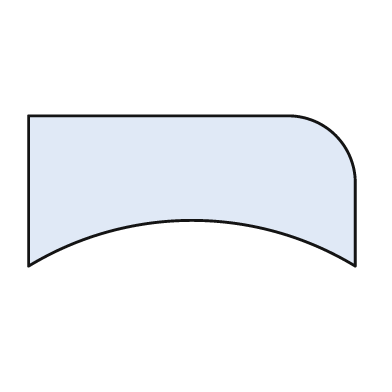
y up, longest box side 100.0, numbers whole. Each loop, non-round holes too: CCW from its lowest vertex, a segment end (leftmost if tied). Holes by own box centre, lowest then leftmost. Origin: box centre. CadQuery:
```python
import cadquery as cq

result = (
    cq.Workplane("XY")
    .moveTo(-50.0, -23.0)
    .threePointArc((0.0, -9.0), (50.0, -23.0))
    .lineTo(50.0, 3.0)
    .threePointArc((44.0, 17.0), (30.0, 23.0))
    .lineTo(-50.0, 23.0)
    .close()
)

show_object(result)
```